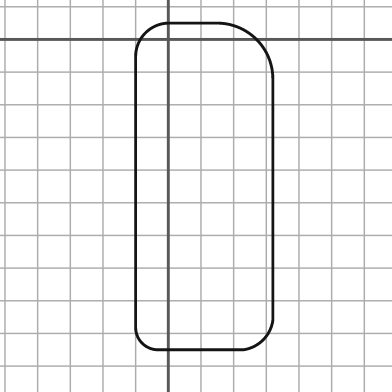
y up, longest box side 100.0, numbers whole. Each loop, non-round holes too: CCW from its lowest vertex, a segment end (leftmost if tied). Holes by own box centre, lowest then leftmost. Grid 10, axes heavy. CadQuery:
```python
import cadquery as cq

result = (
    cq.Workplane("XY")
    .moveTo(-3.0, -95.0)
    .lineTo(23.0, -95.0)
    .threePointArc((29.0, -92.0), (32.0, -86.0))
    .lineTo(32.0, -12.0)
    .threePointArc((27.0, 0.0), (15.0, 5.0))
    .lineTo(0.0, 5.0)
    .threePointArc((-7.0, 2.0), (-10.0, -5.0))
    .lineTo(-10.0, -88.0)
    .threePointArc((-8.0, -93.0), (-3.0, -95.0))
    .close()
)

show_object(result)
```